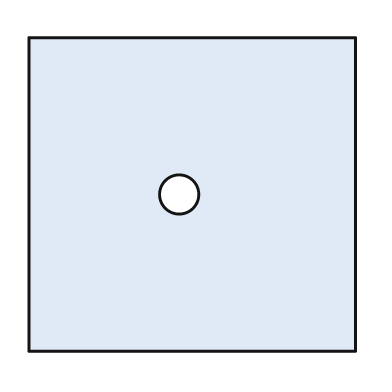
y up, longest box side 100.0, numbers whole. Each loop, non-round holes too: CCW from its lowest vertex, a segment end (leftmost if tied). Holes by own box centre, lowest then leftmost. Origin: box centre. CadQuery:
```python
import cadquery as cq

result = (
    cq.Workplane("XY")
    .moveTo(-50.0, -48.0)
    .lineTo(50.0, -48.0)
    .lineTo(50.0, 48.0)
    .lineTo(-50.0, 48.0)
    .close()
    .moveTo(-4.0, 0.0)
    .circle(6.0)
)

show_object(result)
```